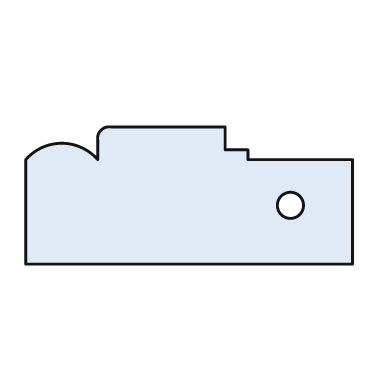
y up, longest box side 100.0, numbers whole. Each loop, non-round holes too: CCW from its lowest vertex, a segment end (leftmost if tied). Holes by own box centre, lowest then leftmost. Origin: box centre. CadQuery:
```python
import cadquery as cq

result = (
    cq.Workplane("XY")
    .moveTo(-50.0, -21.0)
    .lineTo(50.0, -21.0)
    .lineTo(50.0, 11.0)
    .lineTo(18.0, 11.0)
    .lineTo(18.0, 14.0)
    .lineTo(11.0, 14.0)
    .lineTo(11.0, 21.0)
    .lineTo(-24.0, 21.0)
    .threePointArc((-27.0, 20.0), (-28.0, 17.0))
    .lineTo(-28.0, 11.0)
    .threePointArc((-39.0, 16.0), (-50.0, 11.0))
    .close()
    .moveTo(31.0, -3.0)
    .circle(4.0)
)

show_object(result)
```